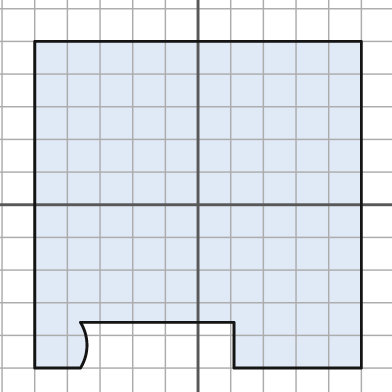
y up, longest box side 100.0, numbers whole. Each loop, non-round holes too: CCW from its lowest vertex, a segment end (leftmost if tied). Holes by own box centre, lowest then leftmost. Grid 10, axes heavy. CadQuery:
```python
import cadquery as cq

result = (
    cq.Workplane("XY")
    .moveTo(-50.0, -50.0)
    .lineTo(-36.0, -50.0)
    .threePointArc((-34.0, -43.0), (-36.0, -36.0))
    .lineTo(11.0, -36.0)
    .lineTo(11.0, -50.0)
    .lineTo(50.0, -50.0)
    .lineTo(50.0, 50.0)
    .lineTo(-50.0, 50.0)
    .close()
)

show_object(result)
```